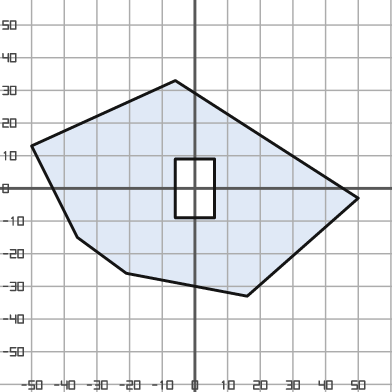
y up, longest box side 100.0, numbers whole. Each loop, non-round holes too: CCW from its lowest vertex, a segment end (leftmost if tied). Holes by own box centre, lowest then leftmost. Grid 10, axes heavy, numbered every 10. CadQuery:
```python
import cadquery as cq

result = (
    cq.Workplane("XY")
    .moveTo(16.0, -33.0)
    .lineTo(50.0, -3.0)
    .lineTo(-6.0, 33.0)
    .lineTo(-50.0, 13.0)
    .lineTo(-36.0, -15.0)
    .lineTo(-21.0, -26.0)
    .close()
    .moveTo(-6.0, -9.0)
    .lineTo(6.0, -9.0)
    .lineTo(6.0, 9.0)
    .lineTo(-6.0, 9.0)
    .close()
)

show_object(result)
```